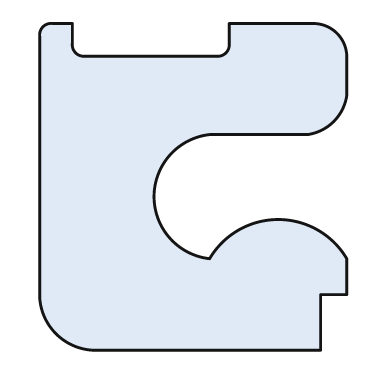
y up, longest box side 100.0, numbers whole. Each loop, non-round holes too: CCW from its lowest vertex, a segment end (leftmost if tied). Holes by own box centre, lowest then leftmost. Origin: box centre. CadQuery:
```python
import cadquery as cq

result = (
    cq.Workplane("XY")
    .moveTo(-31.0, -50.0)
    .lineTo(39.0, -50.0)
    .lineTo(39.0, -33.0)
    .lineTo(47.0, -33.0)
    .lineTo(47.0, -22.0)
    .threePointArc((26.0, -10.0), (5.0, -22.0))
    .threePointArc((-12.0, -3.0), (5.0, 16.0))
    .lineTo(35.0, 16.0)
    .threePointArc((43.0, 20.0), (47.0, 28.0))
    .lineTo(47.0, 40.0)
    .threePointArc((44.0, 47.0), (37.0, 50.0))
    .lineTo(11.0, 50.0)
    .lineTo(11.0, 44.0)
    .threePointArc((10.0, 41.0), (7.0, 40.0))
    .lineTo(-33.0, 40.0)
    .threePointArc((-36.0, 41.0), (-37.0, 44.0))
    .lineTo(-37.0, 50.0)
    .lineTo(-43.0, 50.0)
    .threePointArc((-46.0, 49.0), (-47.0, 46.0))
    .lineTo(-47.0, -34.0)
    .threePointArc((-42.0, -45.0), (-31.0, -50.0))
    .close()
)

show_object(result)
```